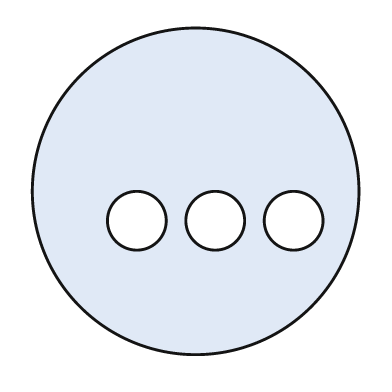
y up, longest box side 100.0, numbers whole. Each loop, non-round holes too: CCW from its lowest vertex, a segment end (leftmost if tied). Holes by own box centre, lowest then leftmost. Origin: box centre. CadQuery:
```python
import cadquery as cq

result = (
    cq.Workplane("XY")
    .moveTo(0.0, 0.0)
    .circle(50.0)
    .moveTo(-18.0, -9.0)
    .circle(9.0)
    .moveTo(6.0, -9.0)
    .circle(9.0)
    .moveTo(30.0, -9.0)
    .circle(9.0)
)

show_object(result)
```